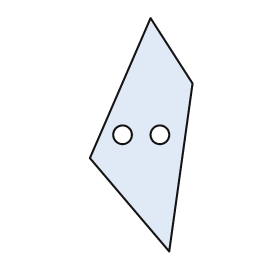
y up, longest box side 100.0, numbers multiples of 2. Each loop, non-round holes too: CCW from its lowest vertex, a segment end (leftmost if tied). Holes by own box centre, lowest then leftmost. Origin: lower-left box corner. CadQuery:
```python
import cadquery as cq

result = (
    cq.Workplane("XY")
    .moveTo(34.0, 0.0)
    .lineTo(44.0, 72.0)
    .lineTo(26.0, 100.0)
    .lineTo(0.0, 40.0)
    .close()
    .moveTo(14.0, 50.0)
    .circle(4.0)
    .moveTo(30.0, 50.0)
    .circle(4.0)
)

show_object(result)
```